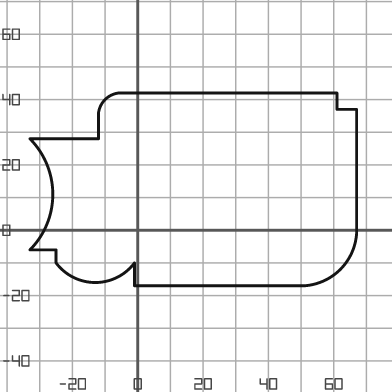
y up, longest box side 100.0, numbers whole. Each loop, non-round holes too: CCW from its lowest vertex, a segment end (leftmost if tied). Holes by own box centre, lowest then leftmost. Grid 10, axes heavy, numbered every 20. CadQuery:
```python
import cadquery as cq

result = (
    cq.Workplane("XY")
    .moveTo(-1.0, -17.0)
    .lineTo(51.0, -17.0)
    .threePointArc((62.0, -12.0), (67.0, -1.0))
    .lineTo(67.0, 37.0)
    .lineTo(61.0, 37.0)
    .lineTo(61.0, 42.0)
    .lineTo(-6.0, 42.0)
    .threePointArc((-10.0, 40.0), (-12.0, 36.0))
    .lineTo(-12.0, 28.0)
    .lineTo(-33.0, 28.0)
    .threePointArc((-26.0, 11.0), (-33.0, -6.0))
    .lineTo(-25.0, -6.0)
    .lineTo(-25.0, -10.0)
    .threePointArc((-13.0, -16.0), (-1.0, -10.0))
    .close()
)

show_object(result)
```